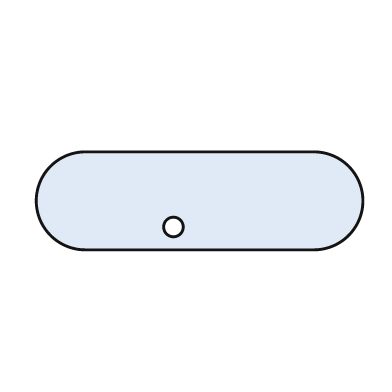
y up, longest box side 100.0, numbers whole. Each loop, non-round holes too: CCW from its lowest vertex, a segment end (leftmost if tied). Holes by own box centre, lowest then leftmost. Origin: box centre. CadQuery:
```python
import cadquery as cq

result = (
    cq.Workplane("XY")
    .moveTo(-35.0, -15.0)
    .lineTo(35.0, -15.0)
    .threePointArc((50.0, 0.0), (35.0, 15.0))
    .lineTo(-35.0, 15.0)
    .threePointArc((-50.0, 0.0), (-35.0, -15.0))
    .close()
    .moveTo(-8.0, -8.0)
    .circle(3.0)
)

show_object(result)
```